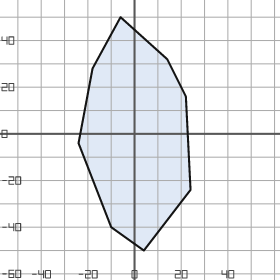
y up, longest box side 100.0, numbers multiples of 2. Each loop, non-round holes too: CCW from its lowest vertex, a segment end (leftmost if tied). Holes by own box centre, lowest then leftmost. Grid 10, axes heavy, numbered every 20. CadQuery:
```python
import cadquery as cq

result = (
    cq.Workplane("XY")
    .moveTo(4.0, -50.0)
    .lineTo(24.0, -24.0)
    .lineTo(22.0, 16.0)
    .lineTo(14.0, 32.0)
    .lineTo(-6.0, 50.0)
    .lineTo(-18.0, 28.0)
    .lineTo(-24.0, -4.0)
    .lineTo(-10.0, -40.0)
    .close()
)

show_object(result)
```